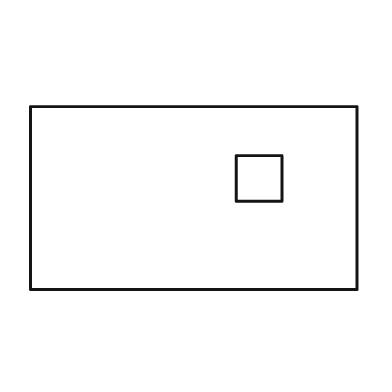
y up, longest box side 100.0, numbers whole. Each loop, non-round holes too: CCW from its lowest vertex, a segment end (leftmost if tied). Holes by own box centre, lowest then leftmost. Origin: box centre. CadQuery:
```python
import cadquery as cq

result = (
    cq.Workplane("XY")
    .moveTo(-50.0, -28.0)
    .lineTo(50.0, -28.0)
    .lineTo(50.0, 28.0)
    .lineTo(-50.0, 28.0)
    .close()
    .moveTo(13.0, -1.0)
    .lineTo(27.0, -1.0)
    .lineTo(27.0, 13.0)
    .lineTo(13.0, 13.0)
    .close()
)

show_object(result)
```